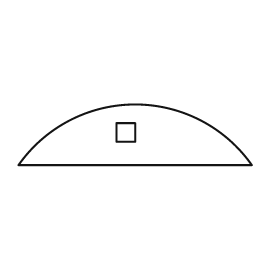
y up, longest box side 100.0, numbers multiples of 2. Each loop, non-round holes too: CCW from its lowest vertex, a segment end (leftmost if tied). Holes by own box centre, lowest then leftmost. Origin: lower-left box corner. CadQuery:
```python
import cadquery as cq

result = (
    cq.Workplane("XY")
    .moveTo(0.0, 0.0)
    .lineTo(100.0, 0.0)
    .threePointArc((50.0, 26.0), (0.0, 0.0))
    .close()
    .moveTo(42.0, 10.0)
    .lineTo(50.0, 10.0)
    .lineTo(50.0, 18.0)
    .lineTo(42.0, 18.0)
    .close()
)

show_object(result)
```